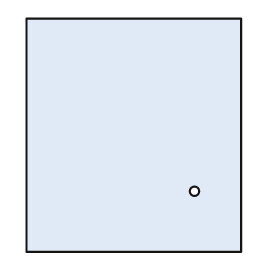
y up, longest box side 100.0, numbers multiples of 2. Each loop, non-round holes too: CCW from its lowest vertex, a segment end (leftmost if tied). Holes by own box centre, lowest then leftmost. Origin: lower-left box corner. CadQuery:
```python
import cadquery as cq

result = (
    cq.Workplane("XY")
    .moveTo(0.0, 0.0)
    .lineTo(92.0, 0.0)
    .lineTo(92.0, 100.0)
    .lineTo(0.0, 100.0)
    .close()
    .moveTo(72.0, 26.0)
    .circle(2.0)
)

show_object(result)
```